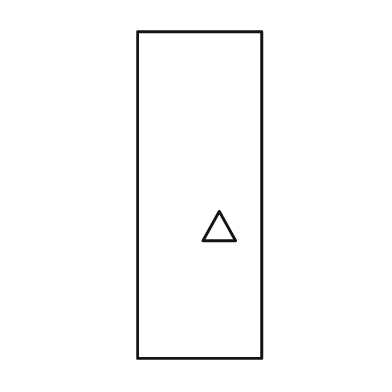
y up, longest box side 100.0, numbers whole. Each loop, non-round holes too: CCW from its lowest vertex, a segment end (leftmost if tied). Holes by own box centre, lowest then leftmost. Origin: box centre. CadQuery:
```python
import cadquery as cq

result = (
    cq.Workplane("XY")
    .moveTo(-19.0, -50.0)
    .lineTo(19.0, -50.0)
    .lineTo(19.0, 50.0)
    .lineTo(-19.0, 50.0)
    .close()
    .moveTo(1.0, -14.0)
    .lineTo(11.0, -14.0)
    .lineTo(6.0, -5.0)
    .close()
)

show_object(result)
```